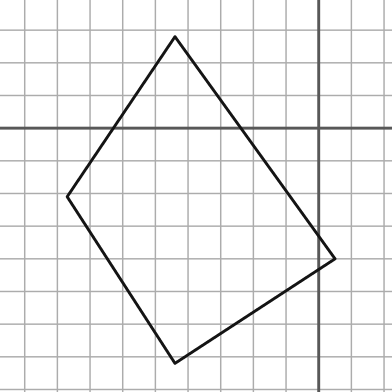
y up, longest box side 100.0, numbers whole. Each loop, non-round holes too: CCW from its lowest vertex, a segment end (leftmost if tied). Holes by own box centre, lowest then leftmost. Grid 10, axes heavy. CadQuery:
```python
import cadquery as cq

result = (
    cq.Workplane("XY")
    .moveTo(-44.0, -72.0)
    .lineTo(5.0, -40.0)
    .lineTo(-44.0, 28.0)
    .lineTo(-77.0, -21.0)
    .close()
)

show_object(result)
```